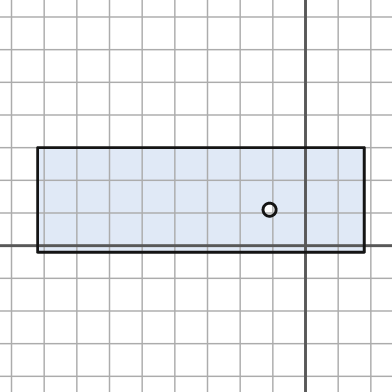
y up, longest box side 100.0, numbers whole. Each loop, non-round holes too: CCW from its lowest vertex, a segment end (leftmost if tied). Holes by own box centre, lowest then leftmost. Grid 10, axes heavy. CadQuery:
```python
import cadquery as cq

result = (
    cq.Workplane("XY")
    .moveTo(-82.0, -2.0)
    .lineTo(18.0, -2.0)
    .lineTo(18.0, 30.0)
    .lineTo(-82.0, 30.0)
    .close()
    .moveTo(-11.0, 11.0)
    .circle(2.0)
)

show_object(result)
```